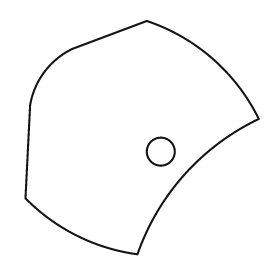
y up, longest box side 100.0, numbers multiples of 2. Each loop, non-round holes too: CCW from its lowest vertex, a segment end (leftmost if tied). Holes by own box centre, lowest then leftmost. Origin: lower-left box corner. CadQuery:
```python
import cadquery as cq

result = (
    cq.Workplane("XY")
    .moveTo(48.0, 0.0)
    .threePointArc((68.0, 34.0), (100.0, 58.0))
    .threePointArc((80.0, 84.0), (52.0, 100.0))
    .lineTo(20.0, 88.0)
    .threePointArc((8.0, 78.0), (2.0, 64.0))
    .lineTo(0.0, 24.0)
    .threePointArc((22.0, 8.0), (48.0, 0.0))
    .close()
    .moveTo(58.0, 44.0)
    .circle(6.0)
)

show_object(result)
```